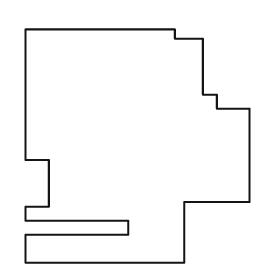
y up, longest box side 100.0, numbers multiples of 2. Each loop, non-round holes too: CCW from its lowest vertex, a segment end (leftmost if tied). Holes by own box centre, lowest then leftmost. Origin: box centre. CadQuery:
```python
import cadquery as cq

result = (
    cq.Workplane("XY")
    .moveTo(-48.0, -50.0)
    .lineTo(20.0, -50.0)
    .lineTo(20.0, -24.0)
    .lineTo(48.0, -24.0)
    .lineTo(48.0, 16.0)
    .lineTo(34.0, 16.0)
    .lineTo(34.0, 22.0)
    .lineTo(28.0, 22.0)
    .lineTo(28.0, 46.0)
    .lineTo(16.0, 46.0)
    .lineTo(16.0, 50.0)
    .lineTo(-48.0, 50.0)
    .lineTo(-48.0, -6.0)
    .lineTo(-38.0, -6.0)
    .lineTo(-38.0, -26.0)
    .lineTo(-48.0, -26.0)
    .lineTo(-48.0, -32.0)
    .lineTo(-4.0, -32.0)
    .lineTo(-4.0, -38.0)
    .lineTo(-48.0, -38.0)
    .close()
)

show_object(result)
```